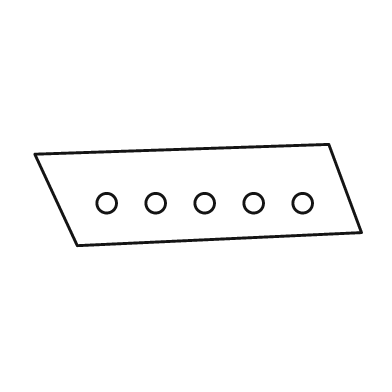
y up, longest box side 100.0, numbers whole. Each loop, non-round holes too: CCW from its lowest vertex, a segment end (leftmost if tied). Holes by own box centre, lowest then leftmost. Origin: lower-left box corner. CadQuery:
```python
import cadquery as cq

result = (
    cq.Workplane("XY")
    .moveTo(13.0, 0.0)
    .lineTo(100.0, 4.0)
    .lineTo(90.0, 31.0)
    .lineTo(0.0, 28.0)
    .close()
    .moveTo(22.0, 13.0)
    .circle(3.0)
    .moveTo(37.0, 13.0)
    .circle(3.0)
    .moveTo(52.0, 13.0)
    .circle(3.0)
    .moveTo(67.0, 13.0)
    .circle(3.0)
    .moveTo(82.0, 13.0)
    .circle(3.0)
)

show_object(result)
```